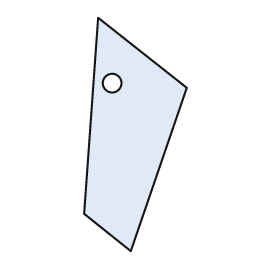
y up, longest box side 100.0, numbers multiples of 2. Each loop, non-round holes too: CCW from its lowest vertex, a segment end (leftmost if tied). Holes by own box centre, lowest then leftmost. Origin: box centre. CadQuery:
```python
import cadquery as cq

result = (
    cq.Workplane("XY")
    .moveTo(-2.0, -50.0)
    .lineTo(22.0, 20.0)
    .lineTo(-16.0, 50.0)
    .lineTo(-22.0, -34.0)
    .close()
    .moveTo(-10.0, 22.0)
    .circle(4.0)
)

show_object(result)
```